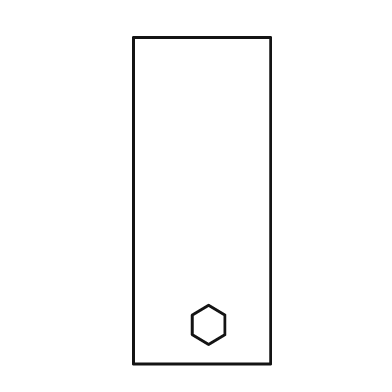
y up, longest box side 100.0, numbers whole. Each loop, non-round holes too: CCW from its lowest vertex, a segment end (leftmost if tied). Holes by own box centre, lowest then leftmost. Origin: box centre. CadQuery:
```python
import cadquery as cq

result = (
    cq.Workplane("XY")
    .moveTo(-21.0, -50.0)
    .lineTo(21.0, -50.0)
    .lineTo(21.0, 50.0)
    .lineTo(-21.0, 50.0)
    .close()
    .moveTo(2.0, -44.0)
    .lineTo(7.0, -41.0)
    .lineTo(7.0, -35.0)
    .lineTo(2.0, -32.0)
    .lineTo(-3.0, -35.0)
    .lineTo(-3.0, -41.0)
    .close()
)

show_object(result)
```